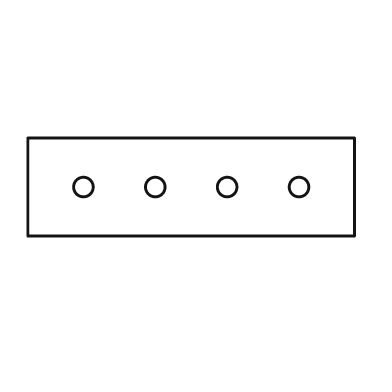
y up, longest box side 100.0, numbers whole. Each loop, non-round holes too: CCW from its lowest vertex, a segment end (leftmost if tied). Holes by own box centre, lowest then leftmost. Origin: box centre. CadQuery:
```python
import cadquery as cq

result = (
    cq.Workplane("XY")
    .moveTo(-50.0, -15.0)
    .lineTo(50.0, -15.0)
    .lineTo(50.0, 15.0)
    .lineTo(-50.0, 15.0)
    .close()
    .moveTo(-33.0, 0.0)
    .circle(3.0)
    .moveTo(-11.0, 0.0)
    .circle(3.0)
    .moveTo(11.0, 0.0)
    .circle(3.0)
    .moveTo(33.0, 0.0)
    .circle(3.0)
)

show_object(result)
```